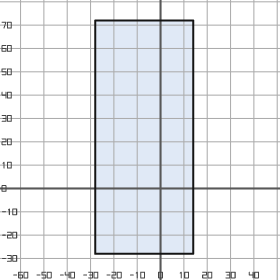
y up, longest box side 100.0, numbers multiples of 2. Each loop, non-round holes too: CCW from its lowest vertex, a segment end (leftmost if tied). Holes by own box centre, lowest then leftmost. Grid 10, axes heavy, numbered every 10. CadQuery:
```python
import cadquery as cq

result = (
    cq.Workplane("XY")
    .moveTo(-28.0, -28.0)
    .lineTo(14.0, -28.0)
    .lineTo(14.0, 72.0)
    .lineTo(-28.0, 72.0)
    .close()
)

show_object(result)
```